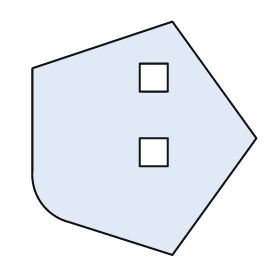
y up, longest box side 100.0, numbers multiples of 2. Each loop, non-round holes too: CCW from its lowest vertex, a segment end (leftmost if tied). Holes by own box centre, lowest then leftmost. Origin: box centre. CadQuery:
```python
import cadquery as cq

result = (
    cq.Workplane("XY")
    .moveTo(12.0, -50.0)
    .lineTo(48.0, 0.0)
    .lineTo(12.0, 50.0)
    .lineTo(-48.0, 30.0)
    .lineTo(-48.0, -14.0)
    .threePointArc((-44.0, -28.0), (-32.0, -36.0))
    .close()
    .moveTo(-2.0, -12.0)
    .lineTo(10.0, -12.0)
    .lineTo(10.0, 0.0)
    .lineTo(-2.0, 0.0)
    .close()
    .moveTo(-2.0, 20.0)
    .lineTo(10.0, 20.0)
    .lineTo(10.0, 32.0)
    .lineTo(-2.0, 32.0)
    .close()
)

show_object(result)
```